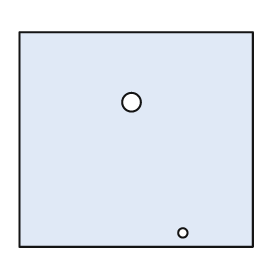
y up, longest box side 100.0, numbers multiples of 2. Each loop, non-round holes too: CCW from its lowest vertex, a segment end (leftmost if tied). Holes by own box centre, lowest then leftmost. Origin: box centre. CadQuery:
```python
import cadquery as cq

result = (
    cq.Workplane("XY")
    .moveTo(-50.0, -46.0)
    .lineTo(50.0, -46.0)
    .lineTo(50.0, 46.0)
    .lineTo(-50.0, 46.0)
    .close()
    .moveTo(20.0, -40.0)
    .circle(2.0)
    .moveTo(-2.0, 16.0)
    .circle(4.0)
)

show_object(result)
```